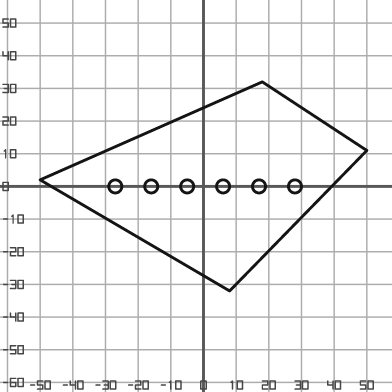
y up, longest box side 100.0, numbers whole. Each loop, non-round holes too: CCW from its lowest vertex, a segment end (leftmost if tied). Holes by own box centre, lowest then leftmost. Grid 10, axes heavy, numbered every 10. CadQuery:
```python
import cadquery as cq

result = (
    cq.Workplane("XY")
    .moveTo(8.0, -32.0)
    .lineTo(50.0, 11.0)
    .lineTo(18.0, 32.0)
    .lineTo(-50.0, 2.0)
    .close()
    .moveTo(-27.0, 0.0)
    .circle(2.0)
    .moveTo(-16.0, 0.0)
    .circle(2.0)
    .moveTo(-5.0, 0.0)
    .circle(2.0)
    .moveTo(6.0, 0.0)
    .circle(2.0)
    .moveTo(17.0, 0.0)
    .circle(2.0)
    .moveTo(28.0, 0.0)
    .circle(2.0)
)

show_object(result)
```